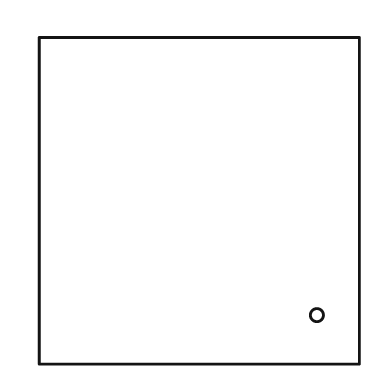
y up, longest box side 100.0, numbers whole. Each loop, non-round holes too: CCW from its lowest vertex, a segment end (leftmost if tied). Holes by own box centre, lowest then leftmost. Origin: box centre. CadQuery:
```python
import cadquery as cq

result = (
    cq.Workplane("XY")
    .moveTo(-49.0, -50.0)
    .lineTo(49.0, -50.0)
    .lineTo(49.0, 50.0)
    .lineTo(-49.0, 50.0)
    .close()
    .moveTo(36.0, -35.0)
    .circle(2.0)
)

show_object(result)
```